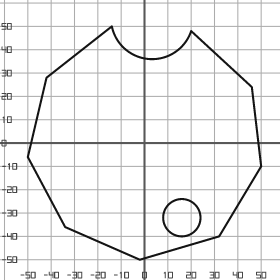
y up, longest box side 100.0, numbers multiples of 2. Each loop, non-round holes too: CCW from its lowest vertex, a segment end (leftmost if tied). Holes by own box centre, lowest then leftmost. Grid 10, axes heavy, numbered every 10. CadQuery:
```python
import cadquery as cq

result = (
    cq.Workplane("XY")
    .moveTo(-2.0, -50.0)
    .lineTo(32.0, -40.0)
    .lineTo(50.0, -10.0)
    .lineTo(46.0, 24.0)
    .lineTo(20.0, 48.0)
    .threePointArc((2.0, 36.0), (-14.0, 50.0))
    .lineTo(-42.0, 28.0)
    .lineTo(-50.0, -6.0)
    .lineTo(-34.0, -36.0)
    .close()
    .moveTo(16.0, -32.0)
    .circle(8.0)
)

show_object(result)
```